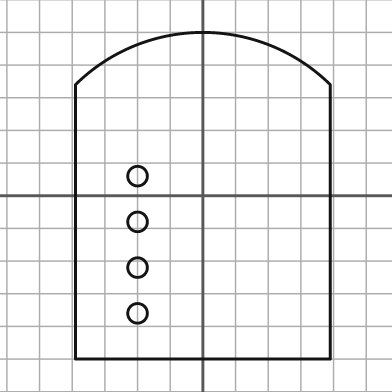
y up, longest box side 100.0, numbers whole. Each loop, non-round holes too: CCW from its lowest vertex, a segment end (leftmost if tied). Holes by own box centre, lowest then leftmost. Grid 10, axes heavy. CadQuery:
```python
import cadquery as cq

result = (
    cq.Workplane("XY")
    .moveTo(-39.0, -50.0)
    .lineTo(39.0, -50.0)
    .lineTo(39.0, 34.0)
    .threePointArc((0.0, 50.0), (-39.0, 34.0))
    .close()
    .moveTo(-20.0, -36.0)
    .circle(3.0)
    .moveTo(-20.0, -22.0)
    .circle(3.0)
    .moveTo(-20.0, -8.0)
    .circle(3.0)
    .moveTo(-20.0, 6.0)
    .circle(3.0)
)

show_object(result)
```